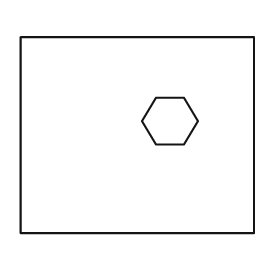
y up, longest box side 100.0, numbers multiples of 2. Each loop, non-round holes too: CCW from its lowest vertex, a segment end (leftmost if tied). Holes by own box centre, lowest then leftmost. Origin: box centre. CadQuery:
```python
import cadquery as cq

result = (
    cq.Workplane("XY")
    .moveTo(-50.0, -42.0)
    .lineTo(50.0, -42.0)
    .lineTo(50.0, 42.0)
    .lineTo(-50.0, 42.0)
    .close()
    .moveTo(8.0, -4.0)
    .lineTo(20.0, -4.0)
    .lineTo(26.0, 6.0)
    .lineTo(20.0, 16.0)
    .lineTo(8.0, 16.0)
    .lineTo(2.0, 6.0)
    .close()
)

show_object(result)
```